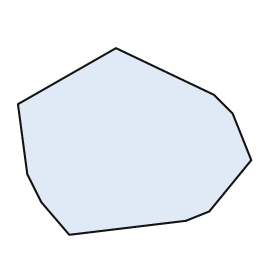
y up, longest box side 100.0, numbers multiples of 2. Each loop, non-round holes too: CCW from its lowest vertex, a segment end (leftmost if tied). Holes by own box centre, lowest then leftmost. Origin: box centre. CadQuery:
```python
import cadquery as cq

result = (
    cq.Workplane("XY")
    .moveTo(-28.0, -40.0)
    .lineTo(22.0, -34.0)
    .lineTo(32.0, -30.0)
    .lineTo(50.0, -8.0)
    .lineTo(42.0, 12.0)
    .lineTo(34.0, 20.0)
    .lineTo(-8.0, 40.0)
    .lineTo(-50.0, 16.0)
    .lineTo(-46.0, -14.0)
    .lineTo(-40.0, -26.0)
    .close()
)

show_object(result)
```